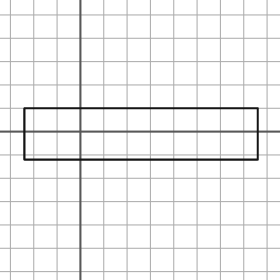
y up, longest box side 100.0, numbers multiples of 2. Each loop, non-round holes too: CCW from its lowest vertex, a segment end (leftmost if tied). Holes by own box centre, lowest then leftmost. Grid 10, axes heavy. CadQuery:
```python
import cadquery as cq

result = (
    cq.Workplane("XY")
    .moveTo(-24.0, -12.0)
    .lineTo(76.0, -12.0)
    .lineTo(76.0, 10.0)
    .lineTo(-24.0, 10.0)
    .close()
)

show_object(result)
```